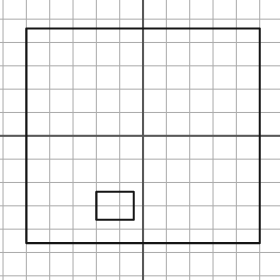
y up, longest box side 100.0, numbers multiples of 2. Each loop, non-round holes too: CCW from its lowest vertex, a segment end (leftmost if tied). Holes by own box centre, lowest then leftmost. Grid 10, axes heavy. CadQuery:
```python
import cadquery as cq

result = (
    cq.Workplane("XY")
    .moveTo(-50.0, -46.0)
    .lineTo(50.0, -46.0)
    .lineTo(50.0, 46.0)
    .lineTo(-50.0, 46.0)
    .close()
    .moveTo(-20.0, -36.0)
    .lineTo(-4.0, -36.0)
    .lineTo(-4.0, -24.0)
    .lineTo(-20.0, -24.0)
    .close()
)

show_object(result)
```